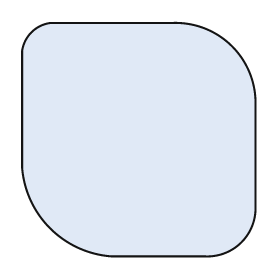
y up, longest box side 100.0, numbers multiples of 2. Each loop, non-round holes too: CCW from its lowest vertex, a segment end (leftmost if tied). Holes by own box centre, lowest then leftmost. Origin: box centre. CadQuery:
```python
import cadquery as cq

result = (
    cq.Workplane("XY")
    .moveTo(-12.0, -50.0)
    .lineTo(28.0, -50.0)
    .threePointArc((44.0, -44.0), (50.0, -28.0))
    .lineTo(50.0, 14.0)
    .threePointArc((40.0, 40.0), (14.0, 50.0))
    .lineTo(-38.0, 50.0)
    .threePointArc((-46.0, 46.0), (-50.0, 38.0))
    .lineTo(-50.0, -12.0)
    .threePointArc((-38.0, -38.0), (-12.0, -50.0))
    .close()
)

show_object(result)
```